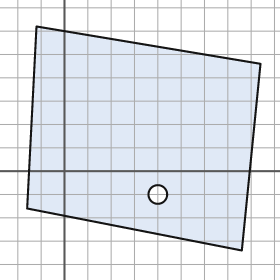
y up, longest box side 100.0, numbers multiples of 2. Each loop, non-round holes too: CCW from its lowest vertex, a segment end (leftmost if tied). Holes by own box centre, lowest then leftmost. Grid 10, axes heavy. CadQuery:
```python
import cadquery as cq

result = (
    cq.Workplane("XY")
    .moveTo(76.0, -34.0)
    .lineTo(84.0, 46.0)
    .lineTo(-12.0, 62.0)
    .lineTo(-16.0, -16.0)
    .close()
    .moveTo(40.0, -10.0)
    .circle(4.0)
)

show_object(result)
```